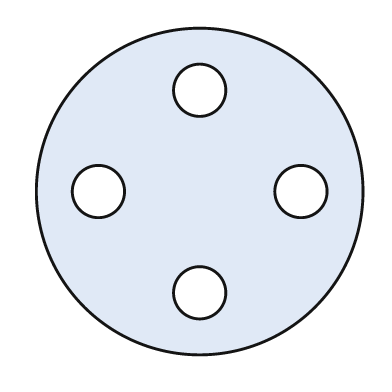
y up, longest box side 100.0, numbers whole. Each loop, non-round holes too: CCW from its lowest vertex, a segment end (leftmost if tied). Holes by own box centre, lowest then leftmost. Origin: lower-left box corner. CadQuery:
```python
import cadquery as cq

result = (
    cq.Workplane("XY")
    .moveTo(50.0, 50.0)
    .circle(50.0)
    .moveTo(50.0, 19.0)
    .circle(8.0)
    .moveTo(19.0, 50.0)
    .circle(8.0)
    .moveTo(81.0, 50.0)
    .circle(8.0)
    .moveTo(50.0, 81.0)
    .circle(8.0)
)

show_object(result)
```